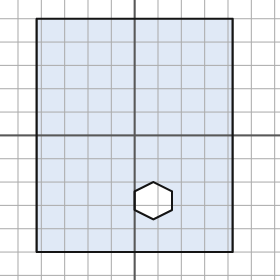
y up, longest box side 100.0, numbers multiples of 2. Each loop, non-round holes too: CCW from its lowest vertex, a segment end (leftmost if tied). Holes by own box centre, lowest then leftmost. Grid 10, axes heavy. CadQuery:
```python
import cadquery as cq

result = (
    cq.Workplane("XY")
    .moveTo(-42.0, -50.0)
    .lineTo(42.0, -50.0)
    .lineTo(42.0, 50.0)
    .lineTo(-42.0, 50.0)
    .close()
    .moveTo(8.0, -36.0)
    .lineTo(16.0, -32.0)
    .lineTo(16.0, -24.0)
    .lineTo(8.0, -20.0)
    .lineTo(0.0, -24.0)
    .lineTo(0.0, -32.0)
    .close()
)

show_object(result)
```